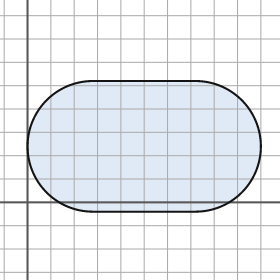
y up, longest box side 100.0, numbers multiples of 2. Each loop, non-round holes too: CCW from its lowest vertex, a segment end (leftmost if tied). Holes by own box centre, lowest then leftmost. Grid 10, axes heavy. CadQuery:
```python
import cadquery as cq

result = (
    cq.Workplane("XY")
    .moveTo(28.0, -4.0)
    .lineTo(72.0, -4.0)
    .threePointArc((100.0, 24.0), (72.0, 52.0))
    .lineTo(28.0, 52.0)
    .threePointArc((0.0, 24.0), (28.0, -4.0))
    .close()
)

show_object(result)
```